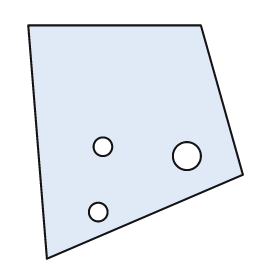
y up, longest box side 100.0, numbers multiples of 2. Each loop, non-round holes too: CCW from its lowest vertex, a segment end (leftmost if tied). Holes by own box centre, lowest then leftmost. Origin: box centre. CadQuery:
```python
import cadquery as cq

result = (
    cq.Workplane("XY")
    .moveTo(-38.0, -50.0)
    .lineTo(46.0, -14.0)
    .lineTo(28.0, 50.0)
    .lineTo(-46.0, 50.0)
    .close()
    .moveTo(-16.0, -30.0)
    .circle(4.0)
    .moveTo(22.0, -6.0)
    .circle(6.0)
    .moveTo(-14.0, -2.0)
    .circle(4.0)
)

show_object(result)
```